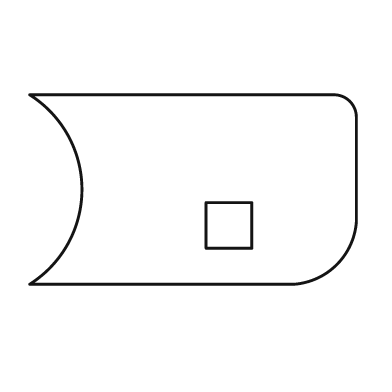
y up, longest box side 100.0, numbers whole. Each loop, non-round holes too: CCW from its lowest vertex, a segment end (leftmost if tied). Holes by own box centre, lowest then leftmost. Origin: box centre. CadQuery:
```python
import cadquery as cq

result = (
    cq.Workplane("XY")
    .moveTo(-50.0, -29.0)
    .lineTo(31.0, -29.0)
    .threePointArc((44.0, -23.0), (50.0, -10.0))
    .lineTo(50.0, 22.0)
    .threePointArc((48.0, 27.0), (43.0, 29.0))
    .lineTo(-50.0, 29.0)
    .threePointArc((-34.0, 0.0), (-50.0, -29.0))
    .close()
    .moveTo(4.0, -18.0)
    .lineTo(18.0, -18.0)
    .lineTo(18.0, -4.0)
    .lineTo(4.0, -4.0)
    .close()
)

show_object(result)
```